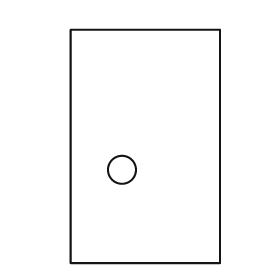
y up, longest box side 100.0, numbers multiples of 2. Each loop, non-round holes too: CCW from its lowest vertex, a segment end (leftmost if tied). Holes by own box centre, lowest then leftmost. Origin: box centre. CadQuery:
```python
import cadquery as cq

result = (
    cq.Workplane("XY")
    .moveTo(-32.0, -50.0)
    .lineTo(32.0, -50.0)
    .lineTo(32.0, 50.0)
    .lineTo(-32.0, 50.0)
    .close()
    .moveTo(-10.0, -10.0)
    .circle(6.0)
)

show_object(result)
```